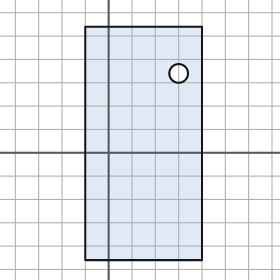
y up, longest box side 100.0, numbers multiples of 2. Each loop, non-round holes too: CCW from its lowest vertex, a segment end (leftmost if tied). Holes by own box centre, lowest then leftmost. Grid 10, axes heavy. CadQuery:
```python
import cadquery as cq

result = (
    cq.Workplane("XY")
    .moveTo(-10.0, -46.0)
    .lineTo(40.0, -46.0)
    .lineTo(40.0, 54.0)
    .lineTo(-10.0, 54.0)
    .close()
    .moveTo(30.0, 34.0)
    .circle(4.0)
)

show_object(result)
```